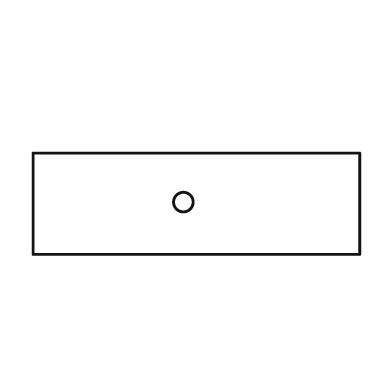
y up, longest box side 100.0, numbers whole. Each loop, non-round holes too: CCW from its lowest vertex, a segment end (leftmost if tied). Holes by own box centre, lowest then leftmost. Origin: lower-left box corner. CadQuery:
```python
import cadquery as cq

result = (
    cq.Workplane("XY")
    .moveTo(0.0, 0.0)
    .lineTo(100.0, 0.0)
    .lineTo(100.0, 31.0)
    .lineTo(0.0, 31.0)
    .close()
    .moveTo(46.0, 16.0)
    .circle(3.0)
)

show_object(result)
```